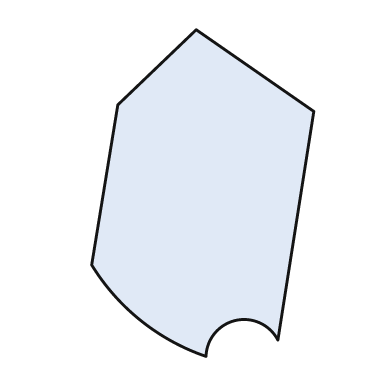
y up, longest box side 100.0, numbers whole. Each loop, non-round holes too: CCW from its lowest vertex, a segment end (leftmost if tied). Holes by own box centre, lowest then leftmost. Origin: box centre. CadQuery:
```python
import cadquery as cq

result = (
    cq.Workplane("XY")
    .moveTo(1.0, -50.0)
    .threePointArc((10.0, -39.0), (23.0, -45.0))
    .lineTo(34.0, 25.0)
    .lineTo(-2.0, 50.0)
    .lineTo(-26.0, 27.0)
    .lineTo(-34.0, -22.0)
    .threePointArc((-19.0, -39.0), (1.0, -50.0))
    .close()
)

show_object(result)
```